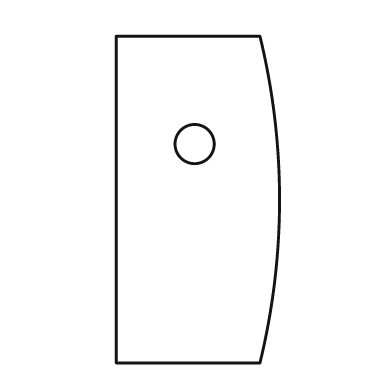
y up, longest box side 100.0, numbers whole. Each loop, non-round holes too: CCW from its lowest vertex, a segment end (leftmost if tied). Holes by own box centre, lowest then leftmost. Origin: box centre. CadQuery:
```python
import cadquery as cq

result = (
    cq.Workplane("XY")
    .moveTo(-25.0, -50.0)
    .lineTo(19.0, -50.0)
    .threePointArc((25.0, 0.0), (19.0, 50.0))
    .lineTo(-25.0, 50.0)
    .close()
    .moveTo(-1.0, 17.0)
    .circle(6.0)
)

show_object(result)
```